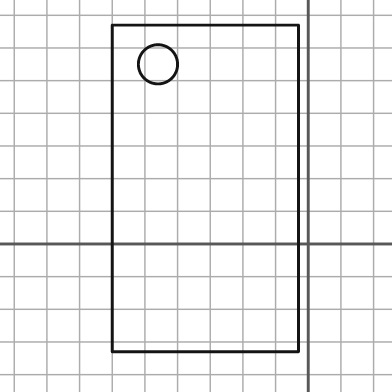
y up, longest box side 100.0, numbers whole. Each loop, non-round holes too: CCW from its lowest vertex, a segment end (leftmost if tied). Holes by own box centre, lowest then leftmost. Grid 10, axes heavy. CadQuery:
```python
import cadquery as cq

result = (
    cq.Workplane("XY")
    .moveTo(-60.0, -33.0)
    .lineTo(-3.0, -33.0)
    .lineTo(-3.0, 67.0)
    .lineTo(-60.0, 67.0)
    .close()
    .moveTo(-46.0, 55.0)
    .circle(6.0)
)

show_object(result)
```